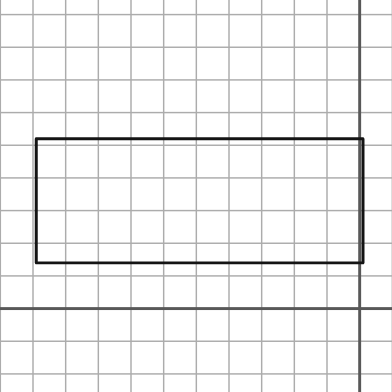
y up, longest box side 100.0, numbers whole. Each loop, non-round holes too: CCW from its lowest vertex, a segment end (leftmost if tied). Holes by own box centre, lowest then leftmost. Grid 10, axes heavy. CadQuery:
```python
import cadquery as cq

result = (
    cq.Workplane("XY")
    .moveTo(-99.0, 14.0)
    .lineTo(1.0, 14.0)
    .lineTo(1.0, 52.0)
    .lineTo(-99.0, 52.0)
    .close()
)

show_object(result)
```